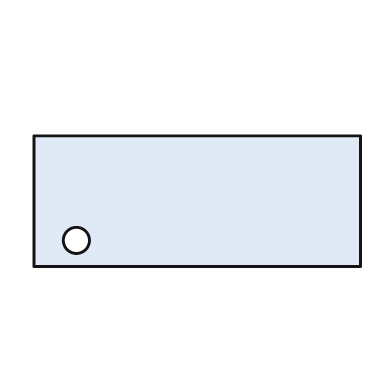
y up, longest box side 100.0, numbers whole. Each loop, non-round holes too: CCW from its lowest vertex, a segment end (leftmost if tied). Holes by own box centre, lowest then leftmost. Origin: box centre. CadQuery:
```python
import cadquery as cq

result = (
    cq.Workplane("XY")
    .moveTo(-50.0, -20.0)
    .lineTo(50.0, -20.0)
    .lineTo(50.0, 20.0)
    .lineTo(-50.0, 20.0)
    .close()
    .moveTo(-37.0, -12.0)
    .circle(4.0)
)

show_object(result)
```